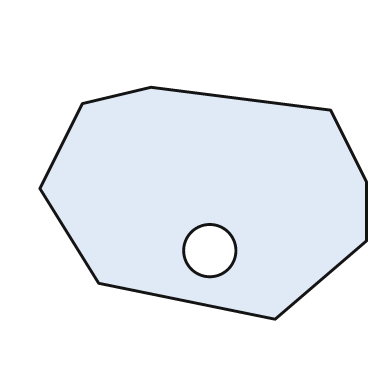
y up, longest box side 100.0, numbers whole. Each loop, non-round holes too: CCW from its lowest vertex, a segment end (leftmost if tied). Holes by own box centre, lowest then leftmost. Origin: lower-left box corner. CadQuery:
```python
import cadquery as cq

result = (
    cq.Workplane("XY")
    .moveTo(72.0, 0.0)
    .lineTo(100.0, 24.0)
    .lineTo(100.0, 42.0)
    .lineTo(89.0, 64.0)
    .lineTo(34.0, 71.0)
    .lineTo(13.0, 66.0)
    .lineTo(0.0, 40.0)
    .lineTo(18.0, 11.0)
    .close()
    .moveTo(52.0, 21.0)
    .circle(8.0)
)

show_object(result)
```